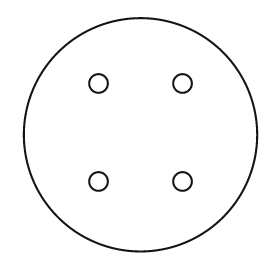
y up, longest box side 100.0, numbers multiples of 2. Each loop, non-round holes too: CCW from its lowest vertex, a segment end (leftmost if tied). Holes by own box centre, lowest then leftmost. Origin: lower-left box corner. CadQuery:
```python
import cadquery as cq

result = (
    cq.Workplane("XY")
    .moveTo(50.0, 50.0)
    .circle(50.0)
    .moveTo(32.0, 30.0)
    .circle(4.0)
    .moveTo(68.0, 30.0)
    .circle(4.0)
    .moveTo(32.0, 72.0)
    .circle(4.0)
    .moveTo(68.0, 72.0)
    .circle(4.0)
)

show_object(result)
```